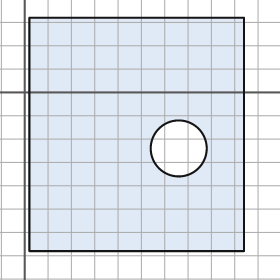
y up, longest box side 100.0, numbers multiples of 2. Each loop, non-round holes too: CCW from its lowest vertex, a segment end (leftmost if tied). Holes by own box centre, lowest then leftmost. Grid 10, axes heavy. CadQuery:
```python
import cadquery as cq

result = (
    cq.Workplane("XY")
    .moveTo(2.0, -68.0)
    .lineTo(94.0, -68.0)
    .lineTo(94.0, 32.0)
    .lineTo(2.0, 32.0)
    .close()
    .moveTo(66.0, -24.0)
    .circle(12.0)
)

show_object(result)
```